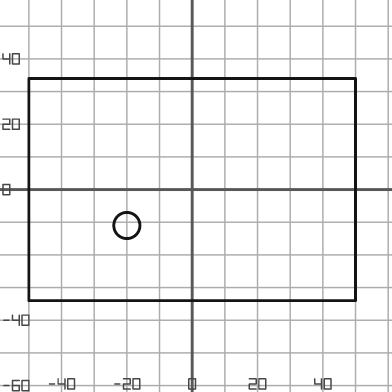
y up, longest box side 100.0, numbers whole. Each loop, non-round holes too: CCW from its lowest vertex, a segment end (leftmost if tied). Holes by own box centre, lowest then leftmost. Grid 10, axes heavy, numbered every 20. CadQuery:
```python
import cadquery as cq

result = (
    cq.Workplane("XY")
    .moveTo(-50.0, -34.0)
    .lineTo(50.0, -34.0)
    .lineTo(50.0, 34.0)
    .lineTo(-50.0, 34.0)
    .close()
    .moveTo(-20.0, -11.0)
    .circle(4.0)
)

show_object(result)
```